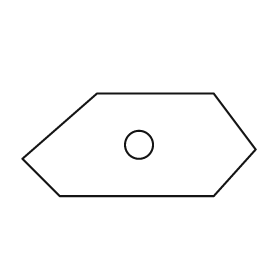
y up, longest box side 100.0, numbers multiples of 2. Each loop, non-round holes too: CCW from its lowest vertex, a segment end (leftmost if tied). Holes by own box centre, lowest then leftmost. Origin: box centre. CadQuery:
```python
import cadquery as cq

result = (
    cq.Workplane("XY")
    .moveTo(-34.0, -22.0)
    .lineTo(32.0, -22.0)
    .lineTo(50.0, -2.0)
    .lineTo(32.0, 22.0)
    .lineTo(-18.0, 22.0)
    .lineTo(-50.0, -6.0)
    .close()
    .moveTo(0.0, 0.0)
    .circle(6.0)
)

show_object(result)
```